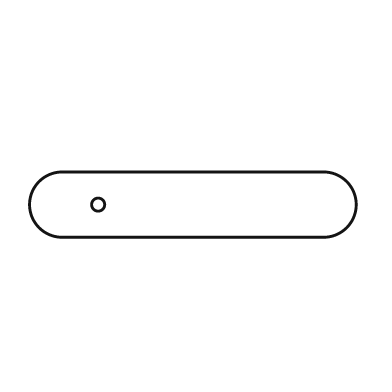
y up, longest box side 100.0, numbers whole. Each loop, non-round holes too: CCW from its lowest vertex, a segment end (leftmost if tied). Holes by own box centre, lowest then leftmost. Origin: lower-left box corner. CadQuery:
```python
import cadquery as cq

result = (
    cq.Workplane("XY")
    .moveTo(10.0, 0.0)
    .lineTo(90.0, 0.0)
    .threePointArc((100.0, 10.0), (90.0, 20.0))
    .lineTo(10.0, 20.0)
    .threePointArc((0.0, 10.0), (10.0, 0.0))
    .close()
    .moveTo(21.0, 10.0)
    .circle(2.0)
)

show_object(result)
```